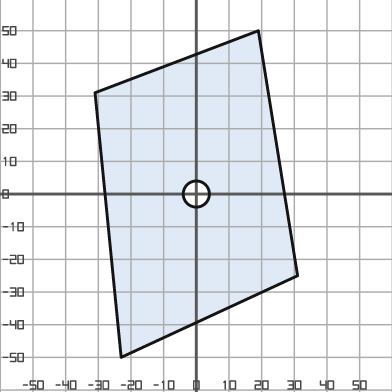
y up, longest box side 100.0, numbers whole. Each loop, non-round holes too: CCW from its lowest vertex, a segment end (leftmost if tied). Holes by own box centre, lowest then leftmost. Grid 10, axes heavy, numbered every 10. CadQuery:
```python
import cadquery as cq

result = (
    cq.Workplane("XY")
    .moveTo(-23.0, -50.0)
    .lineTo(31.0, -25.0)
    .lineTo(19.0, 50.0)
    .lineTo(-31.0, 31.0)
    .close()
    .moveTo(0.0, 0.0)
    .circle(4.0)
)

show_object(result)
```